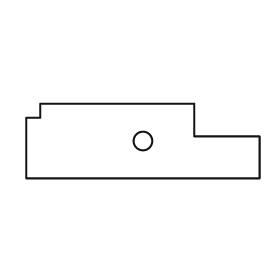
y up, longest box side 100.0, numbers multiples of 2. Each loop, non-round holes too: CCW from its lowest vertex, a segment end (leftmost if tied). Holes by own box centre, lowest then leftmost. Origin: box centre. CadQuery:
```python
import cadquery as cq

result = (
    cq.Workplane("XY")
    .moveTo(-50.0, -16.0)
    .lineTo(50.0, -16.0)
    .lineTo(50.0, 2.0)
    .lineTo(22.0, 2.0)
    .lineTo(22.0, 16.0)
    .lineTo(-44.0, 16.0)
    .lineTo(-44.0, 10.0)
    .lineTo(-50.0, 10.0)
    .close()
    .moveTo(0.0, 0.0)
    .circle(4.0)
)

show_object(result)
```